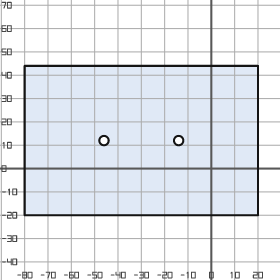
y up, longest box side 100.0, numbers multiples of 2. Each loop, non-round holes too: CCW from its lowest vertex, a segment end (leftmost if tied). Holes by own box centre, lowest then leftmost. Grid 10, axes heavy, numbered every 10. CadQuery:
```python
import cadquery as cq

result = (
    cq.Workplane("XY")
    .moveTo(-80.0, -20.0)
    .lineTo(20.0, -20.0)
    .lineTo(20.0, 44.0)
    .lineTo(-80.0, 44.0)
    .close()
    .moveTo(-46.0, 12.0)
    .circle(2.0)
    .moveTo(-14.0, 12.0)
    .circle(2.0)
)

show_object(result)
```